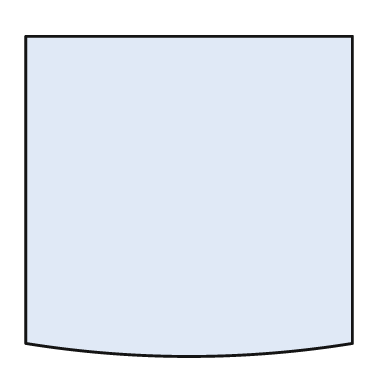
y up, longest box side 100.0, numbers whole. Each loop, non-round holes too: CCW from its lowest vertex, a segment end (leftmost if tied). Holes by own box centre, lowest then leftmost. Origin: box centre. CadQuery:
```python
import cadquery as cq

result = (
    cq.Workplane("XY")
    .moveTo(-50.0, -45.0)
    .threePointArc((0.0, -49.0), (50.0, -45.0))
    .lineTo(50.0, 49.0)
    .lineTo(-50.0, 49.0)
    .close()
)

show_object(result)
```